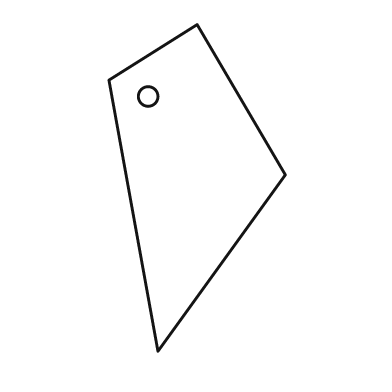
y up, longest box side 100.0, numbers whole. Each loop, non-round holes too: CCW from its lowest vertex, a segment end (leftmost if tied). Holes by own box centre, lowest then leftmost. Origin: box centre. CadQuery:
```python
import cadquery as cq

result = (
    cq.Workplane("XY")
    .moveTo(-12.0, -50.0)
    .lineTo(27.0, 4.0)
    .lineTo(0.0, 50.0)
    .lineTo(-27.0, 33.0)
    .close()
    .moveTo(-15.0, 28.0)
    .circle(3.0)
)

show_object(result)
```